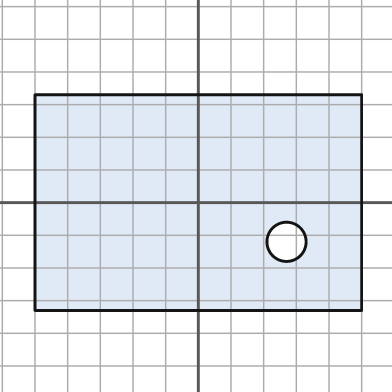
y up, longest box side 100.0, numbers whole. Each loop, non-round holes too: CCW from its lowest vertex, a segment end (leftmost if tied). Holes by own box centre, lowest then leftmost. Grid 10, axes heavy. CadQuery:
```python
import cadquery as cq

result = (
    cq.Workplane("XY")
    .moveTo(-50.0, -33.0)
    .lineTo(50.0, -33.0)
    .lineTo(50.0, 33.0)
    .lineTo(-50.0, 33.0)
    .close()
    .moveTo(27.0, -12.0)
    .circle(6.0)
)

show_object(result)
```